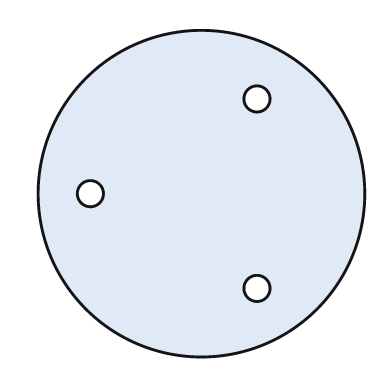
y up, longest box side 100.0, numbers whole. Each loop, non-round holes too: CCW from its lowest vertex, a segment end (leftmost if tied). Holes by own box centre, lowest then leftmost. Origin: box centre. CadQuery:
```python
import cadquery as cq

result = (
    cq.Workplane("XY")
    .moveTo(0.0, 0.0)
    .circle(50.0)
    .moveTo(17.0, -29.0)
    .circle(4.0)
    .moveTo(-34.0, 0.0)
    .circle(4.0)
    .moveTo(17.0, 29.0)
    .circle(4.0)
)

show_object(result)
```